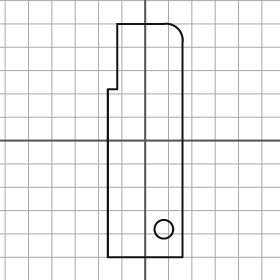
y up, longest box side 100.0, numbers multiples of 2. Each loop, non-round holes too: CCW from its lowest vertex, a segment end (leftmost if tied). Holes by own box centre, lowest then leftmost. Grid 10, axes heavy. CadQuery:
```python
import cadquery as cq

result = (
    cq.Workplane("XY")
    .moveTo(-16.0, -50.0)
    .lineTo(16.0, -50.0)
    .lineTo(16.0, 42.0)
    .threePointArc((14.0, 48.0), (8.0, 50.0))
    .lineTo(-12.0, 50.0)
    .lineTo(-12.0, 22.0)
    .lineTo(-16.0, 22.0)
    .close()
    .moveTo(8.0, -38.0)
    .circle(4.0)
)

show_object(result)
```